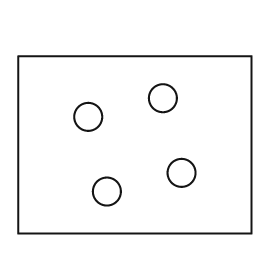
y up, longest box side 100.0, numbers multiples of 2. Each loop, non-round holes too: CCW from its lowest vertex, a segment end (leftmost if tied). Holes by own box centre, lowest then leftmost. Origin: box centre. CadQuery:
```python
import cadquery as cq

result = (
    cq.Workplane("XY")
    .moveTo(-50.0, -38.0)
    .lineTo(50.0, -38.0)
    .lineTo(50.0, 38.0)
    .lineTo(-50.0, 38.0)
    .close()
    .moveTo(-12.0, -20.0)
    .circle(6.0)
    .moveTo(20.0, -12.0)
    .circle(6.0)
    .moveTo(-20.0, 12.0)
    .circle(6.0)
    .moveTo(12.0, 20.0)
    .circle(6.0)
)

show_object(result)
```